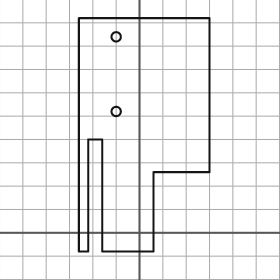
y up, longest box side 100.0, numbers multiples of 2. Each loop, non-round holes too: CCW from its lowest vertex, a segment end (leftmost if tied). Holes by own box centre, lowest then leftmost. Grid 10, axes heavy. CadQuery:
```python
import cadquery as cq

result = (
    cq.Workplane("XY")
    .moveTo(-26.0, -8.0)
    .lineTo(-22.0, -8.0)
    .lineTo(-22.0, 40.0)
    .lineTo(-16.0, 40.0)
    .lineTo(-16.0, -8.0)
    .lineTo(6.0, -8.0)
    .lineTo(6.0, 26.0)
    .lineTo(30.0, 26.0)
    .lineTo(30.0, 92.0)
    .lineTo(-26.0, 92.0)
    .close()
    .moveTo(-10.0, 52.0)
    .circle(2.0)
    .moveTo(-10.0, 84.0)
    .circle(2.0)
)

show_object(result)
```